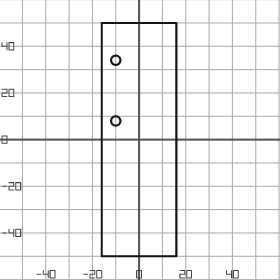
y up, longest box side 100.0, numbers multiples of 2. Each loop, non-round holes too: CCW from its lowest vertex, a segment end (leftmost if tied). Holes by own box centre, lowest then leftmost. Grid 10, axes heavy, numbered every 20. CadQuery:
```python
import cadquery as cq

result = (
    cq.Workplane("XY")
    .moveTo(-16.0, -50.0)
    .lineTo(16.0, -50.0)
    .lineTo(16.0, 50.0)
    .lineTo(-16.0, 50.0)
    .close()
    .moveTo(-10.0, 8.0)
    .circle(2.0)
    .moveTo(-10.0, 34.0)
    .circle(2.0)
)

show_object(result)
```